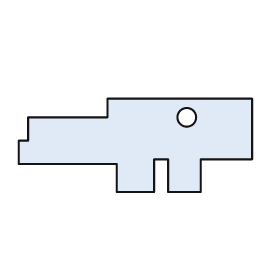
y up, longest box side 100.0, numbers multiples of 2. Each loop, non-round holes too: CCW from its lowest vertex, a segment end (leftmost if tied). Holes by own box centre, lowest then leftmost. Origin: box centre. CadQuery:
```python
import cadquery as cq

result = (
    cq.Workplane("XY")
    .moveTo(-8.0, -20.0)
    .lineTo(8.0, -20.0)
    .lineTo(8.0, -6.0)
    .lineTo(14.0, -6.0)
    .lineTo(14.0, -20.0)
    .lineTo(28.0, -20.0)
    .lineTo(28.0, -6.0)
    .lineTo(50.0, -6.0)
    .lineTo(50.0, 20.0)
    .lineTo(-12.0, 20.0)
    .lineTo(-12.0, 12.0)
    .lineTo(-46.0, 12.0)
    .lineTo(-46.0, 2.0)
    .lineTo(-50.0, 2.0)
    .lineTo(-50.0, -8.0)
    .lineTo(-8.0, -8.0)
    .close()
    .moveTo(22.0, 12.0)
    .circle(4.0)
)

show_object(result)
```